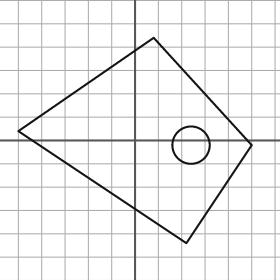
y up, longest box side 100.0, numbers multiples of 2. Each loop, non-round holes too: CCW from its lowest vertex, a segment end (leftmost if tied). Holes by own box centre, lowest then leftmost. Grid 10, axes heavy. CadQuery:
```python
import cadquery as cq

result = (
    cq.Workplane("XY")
    .moveTo(22.0, -44.0)
    .lineTo(50.0, -2.0)
    .lineTo(8.0, 44.0)
    .lineTo(-50.0, 4.0)
    .close()
    .moveTo(24.0, -2.0)
    .circle(8.0)
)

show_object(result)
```